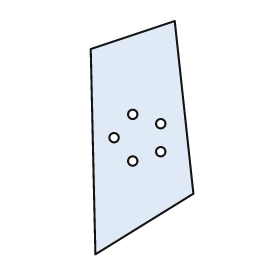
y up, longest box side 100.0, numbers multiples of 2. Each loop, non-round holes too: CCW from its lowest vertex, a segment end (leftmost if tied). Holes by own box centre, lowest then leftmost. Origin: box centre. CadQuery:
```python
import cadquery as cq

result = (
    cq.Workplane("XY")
    .moveTo(-20.0, -50.0)
    .lineTo(22.0, -24.0)
    .lineTo(14.0, 50.0)
    .lineTo(-22.0, 38.0)
    .close()
    .moveTo(-4.0, -10.0)
    .circle(2.0)
    .moveTo(8.0, -6.0)
    .circle(2.0)
    .moveTo(-12.0, 0.0)
    .circle(2.0)
    .moveTo(8.0, 6.0)
    .circle(2.0)
    .moveTo(-4.0, 10.0)
    .circle(2.0)
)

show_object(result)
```